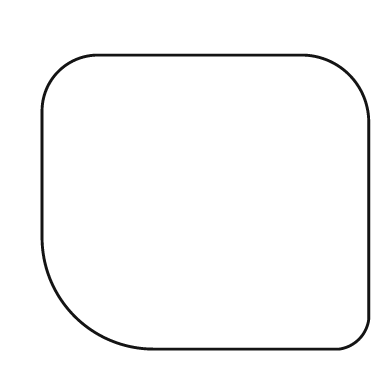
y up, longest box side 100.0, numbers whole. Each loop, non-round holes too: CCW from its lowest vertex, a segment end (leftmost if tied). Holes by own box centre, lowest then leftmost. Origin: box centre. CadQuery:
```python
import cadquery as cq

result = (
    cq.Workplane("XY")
    .moveTo(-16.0, -45.0)
    .lineTo(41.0, -45.0)
    .threePointArc((47.0, -42.0), (50.0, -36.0))
    .lineTo(50.0, 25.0)
    .threePointArc((44.0, 39.0), (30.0, 45.0))
    .lineTo(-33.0, 45.0)
    .threePointArc((-45.0, 40.0), (-50.0, 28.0))
    .lineTo(-50.0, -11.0)
    .threePointArc((-40.0, -35.0), (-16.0, -45.0))
    .close()
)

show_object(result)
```